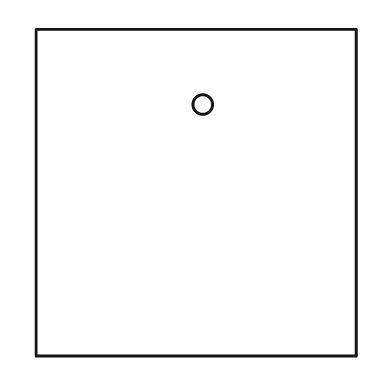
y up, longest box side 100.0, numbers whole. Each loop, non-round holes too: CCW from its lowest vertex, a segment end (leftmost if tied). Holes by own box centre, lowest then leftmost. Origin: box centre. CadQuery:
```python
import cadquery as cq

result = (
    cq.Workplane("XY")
    .moveTo(-49.0, -50.0)
    .lineTo(49.0, -50.0)
    .lineTo(49.0, 50.0)
    .lineTo(-49.0, 50.0)
    .close()
    .moveTo(2.0, 27.0)
    .circle(3.0)
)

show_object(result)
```